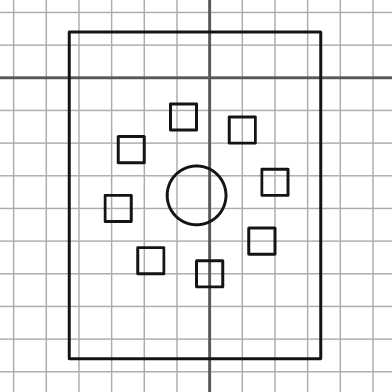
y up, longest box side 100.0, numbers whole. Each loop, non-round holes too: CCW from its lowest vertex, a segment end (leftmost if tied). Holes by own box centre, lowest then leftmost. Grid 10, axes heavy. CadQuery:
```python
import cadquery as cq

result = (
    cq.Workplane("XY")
    .moveTo(-43.0, -86.0)
    .lineTo(34.0, -86.0)
    .lineTo(34.0, 14.0)
    .lineTo(-43.0, 14.0)
    .close()
    .moveTo(-4.0, -64.0)
    .lineTo(4.0, -64.0)
    .lineTo(4.0, -56.0)
    .lineTo(-4.0, -56.0)
    .close()
    .moveTo(-22.0, -60.0)
    .lineTo(-14.0, -60.0)
    .lineTo(-14.0, -52.0)
    .lineTo(-22.0, -52.0)
    .close()
    .moveTo(12.0, -54.0)
    .lineTo(20.0, -54.0)
    .lineTo(20.0, -46.0)
    .lineTo(12.0, -46.0)
    .close()
    .moveTo(-32.0, -44.0)
    .lineTo(-24.0, -44.0)
    .lineTo(-24.0, -36.0)
    .lineTo(-32.0, -36.0)
    .close()
    .moveTo(-4.0, -36.0)
    .circle(9.0)
    .moveTo(16.0, -36.0)
    .lineTo(24.0, -36.0)
    .lineTo(24.0, -28.0)
    .lineTo(16.0, -28.0)
    .close()
    .moveTo(-28.0, -26.0)
    .lineTo(-20.0, -26.0)
    .lineTo(-20.0, -18.0)
    .lineTo(-28.0, -18.0)
    .close()
    .moveTo(6.0, -20.0)
    .lineTo(14.0, -20.0)
    .lineTo(14.0, -12.0)
    .lineTo(6.0, -12.0)
    .close()
    .moveTo(-12.0, -16.0)
    .lineTo(-4.0, -16.0)
    .lineTo(-4.0, -8.0)
    .lineTo(-12.0, -8.0)
    .close()
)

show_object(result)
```